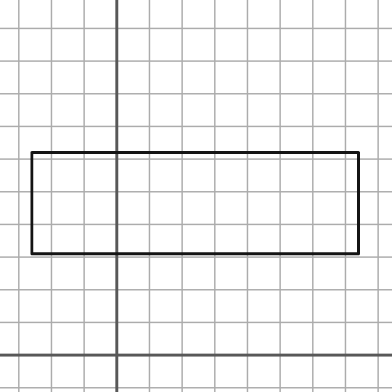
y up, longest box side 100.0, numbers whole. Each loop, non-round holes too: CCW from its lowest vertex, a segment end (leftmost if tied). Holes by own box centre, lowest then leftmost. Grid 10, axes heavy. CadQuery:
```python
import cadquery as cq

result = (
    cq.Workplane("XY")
    .moveTo(-26.0, 31.0)
    .lineTo(74.0, 31.0)
    .lineTo(74.0, 62.0)
    .lineTo(-26.0, 62.0)
    .close()
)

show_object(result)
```